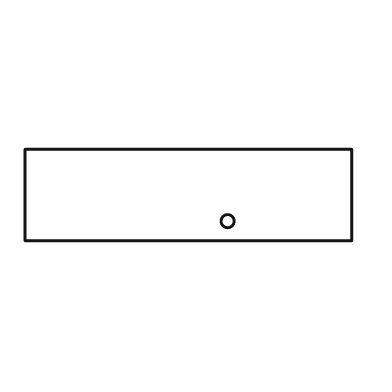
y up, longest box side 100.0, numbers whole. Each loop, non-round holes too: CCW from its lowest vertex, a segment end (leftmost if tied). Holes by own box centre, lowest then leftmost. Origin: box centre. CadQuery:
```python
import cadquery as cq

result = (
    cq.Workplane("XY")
    .moveTo(-50.0, -14.0)
    .lineTo(50.0, -14.0)
    .lineTo(50.0, 14.0)
    .lineTo(-50.0, 14.0)
    .close()
    .moveTo(12.0, -8.0)
    .circle(2.0)
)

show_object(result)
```